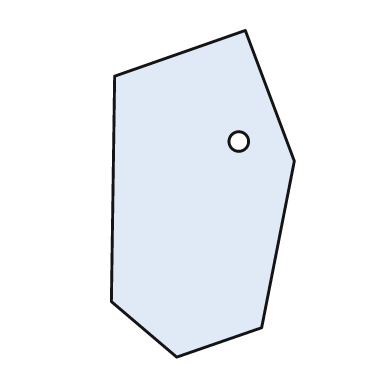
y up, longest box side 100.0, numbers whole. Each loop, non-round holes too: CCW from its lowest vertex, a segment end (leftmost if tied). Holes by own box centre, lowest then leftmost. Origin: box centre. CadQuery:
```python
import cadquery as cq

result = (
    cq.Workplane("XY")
    .moveTo(-8.0, -50.0)
    .lineTo(18.0, -41.0)
    .lineTo(28.0, 10.0)
    .lineTo(13.0, 50.0)
    .lineTo(-27.0, 36.0)
    .lineTo(-28.0, -33.0)
    .close()
    .moveTo(11.0, 16.0)
    .circle(3.0)
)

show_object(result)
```